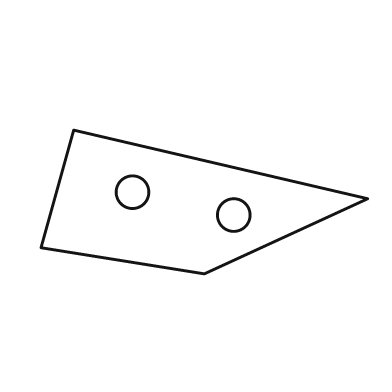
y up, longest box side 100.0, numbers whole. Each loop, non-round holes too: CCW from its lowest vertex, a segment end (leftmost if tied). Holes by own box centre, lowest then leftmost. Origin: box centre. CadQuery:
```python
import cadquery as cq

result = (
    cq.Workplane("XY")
    .moveTo(0.0, -22.0)
    .lineTo(50.0, 1.0)
    .lineTo(-40.0, 22.0)
    .lineTo(-50.0, -14.0)
    .close()
    .moveTo(9.0, -4.0)
    .circle(5.0)
    .moveTo(-22.0, 3.0)
    .circle(5.0)
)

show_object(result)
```